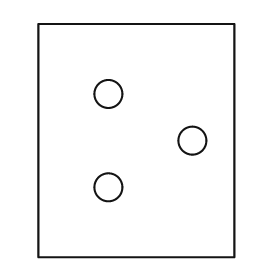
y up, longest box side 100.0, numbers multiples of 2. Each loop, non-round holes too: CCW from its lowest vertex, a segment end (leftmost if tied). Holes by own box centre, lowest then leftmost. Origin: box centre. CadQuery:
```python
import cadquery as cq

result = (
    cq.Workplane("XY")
    .moveTo(-42.0, -50.0)
    .lineTo(42.0, -50.0)
    .lineTo(42.0, 50.0)
    .lineTo(-42.0, 50.0)
    .close()
    .moveTo(-12.0, -20.0)
    .circle(6.0)
    .moveTo(24.0, 0.0)
    .circle(6.0)
    .moveTo(-12.0, 20.0)
    .circle(6.0)
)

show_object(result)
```